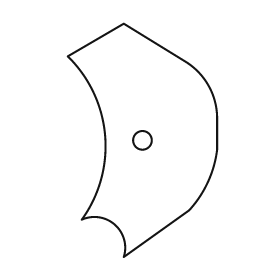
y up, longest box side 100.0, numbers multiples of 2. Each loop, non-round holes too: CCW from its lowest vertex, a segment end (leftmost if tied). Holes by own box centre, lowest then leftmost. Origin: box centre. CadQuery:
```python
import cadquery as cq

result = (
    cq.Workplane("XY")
    .moveTo(-8.0, -50.0)
    .lineTo(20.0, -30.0)
    .threePointArc((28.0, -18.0), (32.0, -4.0))
    .lineTo(32.0, 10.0)
    .threePointArc((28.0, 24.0), (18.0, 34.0))
    .lineTo(-8.0, 50.0)
    .lineTo(-32.0, 36.0)
    .threePointArc((-16.0, 2.0), (-26.0, -34.0))
    .threePointArc((-12.0, -36.0), (-8.0, -50.0))
    .close()
    .moveTo(0.0, 0.0)
    .circle(4.0)
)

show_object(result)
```